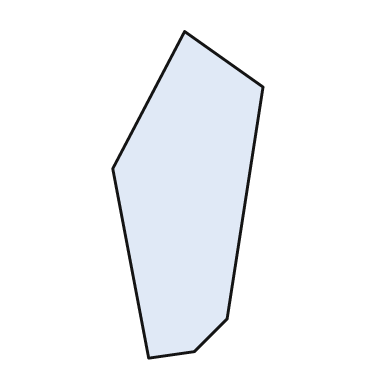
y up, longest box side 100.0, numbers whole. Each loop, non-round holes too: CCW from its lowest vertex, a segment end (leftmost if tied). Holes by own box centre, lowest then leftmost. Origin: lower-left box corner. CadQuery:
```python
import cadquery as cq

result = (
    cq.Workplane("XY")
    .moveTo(11.0, 0.0)
    .lineTo(25.0, 2.0)
    .lineTo(35.0, 12.0)
    .lineTo(46.0, 83.0)
    .lineTo(22.0, 100.0)
    .lineTo(0.0, 58.0)
    .close()
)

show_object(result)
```